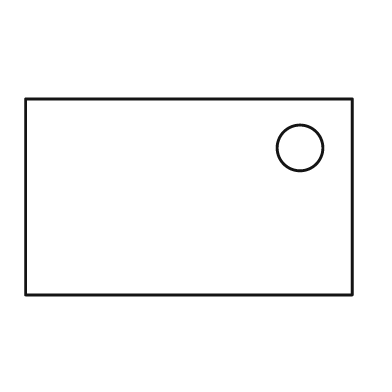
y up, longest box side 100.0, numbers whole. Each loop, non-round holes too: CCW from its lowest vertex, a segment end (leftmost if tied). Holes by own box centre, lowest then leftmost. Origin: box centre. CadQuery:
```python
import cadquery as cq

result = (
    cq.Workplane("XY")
    .moveTo(-50.0, -30.0)
    .lineTo(50.0, -30.0)
    .lineTo(50.0, 30.0)
    .lineTo(-50.0, 30.0)
    .close()
    .moveTo(34.0, 15.0)
    .circle(7.0)
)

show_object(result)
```